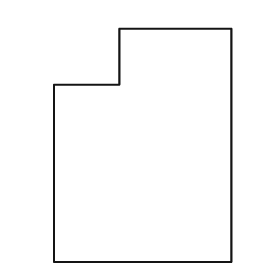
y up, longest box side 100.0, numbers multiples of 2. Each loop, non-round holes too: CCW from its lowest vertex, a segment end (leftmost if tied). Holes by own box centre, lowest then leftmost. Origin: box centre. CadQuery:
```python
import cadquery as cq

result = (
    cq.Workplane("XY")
    .moveTo(-38.0, -50.0)
    .lineTo(38.0, -50.0)
    .lineTo(38.0, 50.0)
    .lineTo(-10.0, 50.0)
    .lineTo(-10.0, 26.0)
    .lineTo(-38.0, 26.0)
    .close()
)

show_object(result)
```